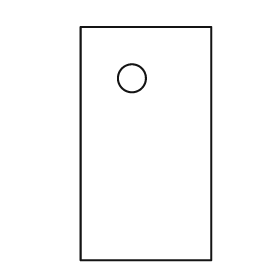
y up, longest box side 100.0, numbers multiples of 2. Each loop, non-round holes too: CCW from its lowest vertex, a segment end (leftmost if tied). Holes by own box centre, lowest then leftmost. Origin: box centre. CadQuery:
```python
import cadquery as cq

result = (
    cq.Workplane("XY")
    .moveTo(-28.0, -50.0)
    .lineTo(28.0, -50.0)
    .lineTo(28.0, 50.0)
    .lineTo(-28.0, 50.0)
    .close()
    .moveTo(-6.0, 28.0)
    .circle(6.0)
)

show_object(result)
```